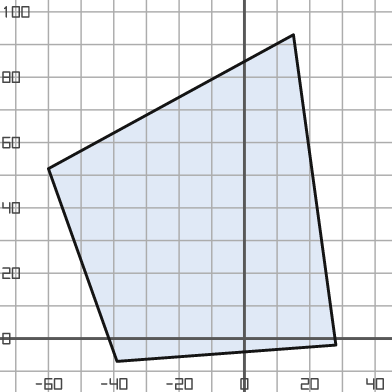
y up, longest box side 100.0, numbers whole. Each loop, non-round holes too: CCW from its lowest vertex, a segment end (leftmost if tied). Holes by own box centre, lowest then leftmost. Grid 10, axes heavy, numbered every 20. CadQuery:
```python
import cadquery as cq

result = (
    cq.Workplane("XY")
    .moveTo(-39.0, -7.0)
    .lineTo(28.0, -2.0)
    .lineTo(15.0, 93.0)
    .lineTo(-60.0, 52.0)
    .close()
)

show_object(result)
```